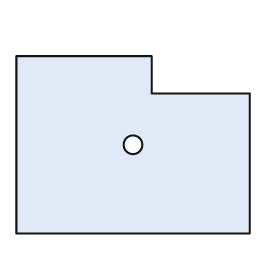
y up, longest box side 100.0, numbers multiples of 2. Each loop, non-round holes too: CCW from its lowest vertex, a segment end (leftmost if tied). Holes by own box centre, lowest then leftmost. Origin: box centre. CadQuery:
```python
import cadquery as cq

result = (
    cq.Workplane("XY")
    .moveTo(-50.0, -38.0)
    .lineTo(50.0, -38.0)
    .lineTo(50.0, 22.0)
    .lineTo(8.0, 22.0)
    .lineTo(8.0, 38.0)
    .lineTo(-50.0, 38.0)
    .close()
    .moveTo(0.0, 0.0)
    .circle(4.0)
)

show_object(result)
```